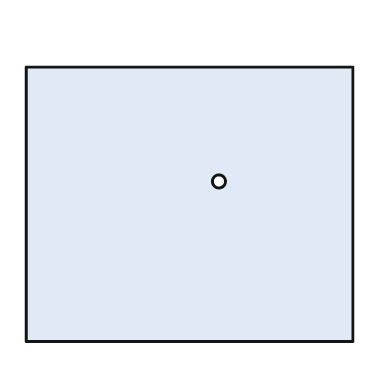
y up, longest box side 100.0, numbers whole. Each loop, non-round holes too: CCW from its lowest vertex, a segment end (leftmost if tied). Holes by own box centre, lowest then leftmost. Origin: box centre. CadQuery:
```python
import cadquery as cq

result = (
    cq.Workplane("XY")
    .moveTo(-50.0, -42.0)
    .lineTo(50.0, -42.0)
    .lineTo(50.0, 42.0)
    .lineTo(-50.0, 42.0)
    .close()
    .moveTo(9.0, 7.0)
    .circle(2.0)
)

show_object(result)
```